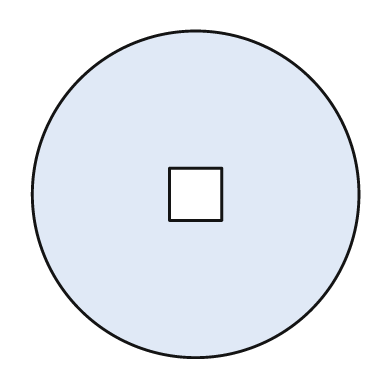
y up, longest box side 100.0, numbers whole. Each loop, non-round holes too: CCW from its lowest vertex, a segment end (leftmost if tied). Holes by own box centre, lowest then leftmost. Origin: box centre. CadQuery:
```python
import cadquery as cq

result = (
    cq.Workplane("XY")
    .moveTo(0.0, 0.0)
    .circle(50.0)
    .moveTo(-8.0, -8.0)
    .lineTo(8.0, -8.0)
    .lineTo(8.0, 8.0)
    .lineTo(-8.0, 8.0)
    .close()
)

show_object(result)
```